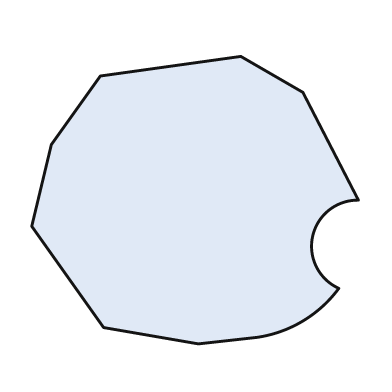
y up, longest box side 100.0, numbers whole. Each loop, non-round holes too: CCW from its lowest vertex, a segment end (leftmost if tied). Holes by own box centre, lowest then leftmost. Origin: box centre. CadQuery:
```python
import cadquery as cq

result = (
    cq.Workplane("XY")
    .moveTo(1.0, -44.0)
    .lineTo(19.0, -42.0)
    .threePointArc((33.0, -37.0), (44.0, -27.0))
    .threePointArc((36.0, -11.0), (50.0, 0.0))
    .lineTo(33.0, 33.0)
    .lineTo(14.0, 44.0)
    .lineTo(-29.0, 38.0)
    .lineTo(-44.0, 17.0)
    .lineTo(-50.0, -8.0)
    .lineTo(-28.0, -39.0)
    .close()
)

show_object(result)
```